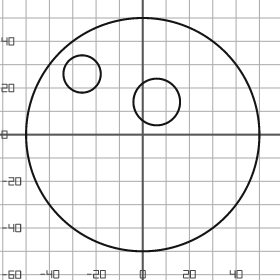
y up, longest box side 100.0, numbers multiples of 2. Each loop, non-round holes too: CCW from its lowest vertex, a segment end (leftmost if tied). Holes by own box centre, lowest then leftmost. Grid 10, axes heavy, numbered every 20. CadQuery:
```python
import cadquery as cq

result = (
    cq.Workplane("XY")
    .moveTo(0.0, 0.0)
    .circle(50.0)
    .moveTo(6.0, 14.0)
    .circle(10.0)
    .moveTo(-26.0, 26.0)
    .circle(8.0)
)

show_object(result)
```